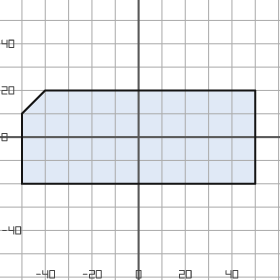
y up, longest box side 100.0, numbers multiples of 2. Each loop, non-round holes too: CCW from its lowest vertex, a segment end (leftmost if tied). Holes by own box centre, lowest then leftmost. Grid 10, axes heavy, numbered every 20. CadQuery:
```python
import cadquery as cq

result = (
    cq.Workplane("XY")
    .moveTo(-50.0, -20.0)
    .lineTo(50.0, -20.0)
    .lineTo(50.0, 20.0)
    .lineTo(-40.0, 20.0)
    .lineTo(-50.0, 10.0)
    .close()
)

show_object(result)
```